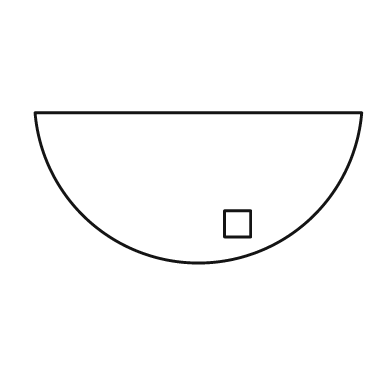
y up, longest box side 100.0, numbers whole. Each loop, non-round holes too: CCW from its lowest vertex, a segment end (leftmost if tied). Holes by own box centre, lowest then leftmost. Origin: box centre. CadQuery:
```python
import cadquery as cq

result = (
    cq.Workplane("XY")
    .moveTo(-50.0, 23.0)
    .threePointArc((0.0, -23.0), (50.0, 23.0))
    .close()
    .moveTo(8.0, -15.0)
    .lineTo(16.0, -15.0)
    .lineTo(16.0, -7.0)
    .lineTo(8.0, -7.0)
    .close()
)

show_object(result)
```